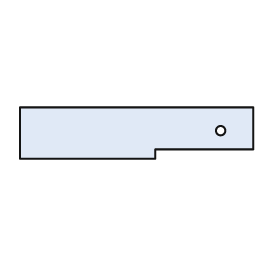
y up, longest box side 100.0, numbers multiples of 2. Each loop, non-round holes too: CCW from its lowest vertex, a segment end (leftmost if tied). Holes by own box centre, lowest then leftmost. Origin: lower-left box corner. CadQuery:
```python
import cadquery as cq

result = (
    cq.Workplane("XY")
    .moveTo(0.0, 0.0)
    .lineTo(58.0, 0.0)
    .lineTo(58.0, 4.0)
    .lineTo(100.0, 4.0)
    .lineTo(100.0, 22.0)
    .lineTo(0.0, 22.0)
    .close()
    .moveTo(86.0, 12.0)
    .circle(2.0)
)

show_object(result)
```